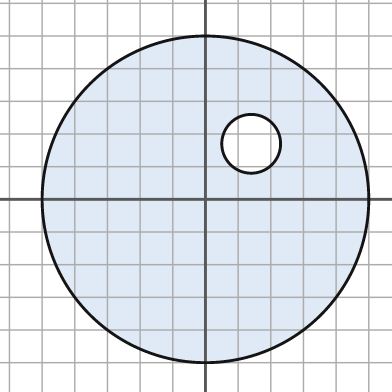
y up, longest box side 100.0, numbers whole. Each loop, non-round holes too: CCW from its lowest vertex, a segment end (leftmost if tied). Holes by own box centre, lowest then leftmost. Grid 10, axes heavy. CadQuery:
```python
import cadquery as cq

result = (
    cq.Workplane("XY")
    .moveTo(0.0, 0.0)
    .circle(50.0)
    .moveTo(14.0, 17.0)
    .circle(9.0)
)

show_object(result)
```